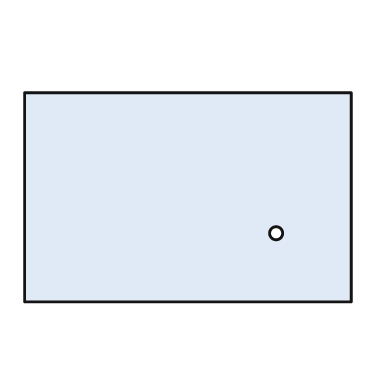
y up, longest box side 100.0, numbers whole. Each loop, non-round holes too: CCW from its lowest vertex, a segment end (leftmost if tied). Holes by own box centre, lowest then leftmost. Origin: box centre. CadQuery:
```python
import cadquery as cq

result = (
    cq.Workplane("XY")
    .moveTo(-50.0, -32.0)
    .lineTo(50.0, -32.0)
    .lineTo(50.0, 32.0)
    .lineTo(-50.0, 32.0)
    .close()
    .moveTo(27.0, -11.0)
    .circle(2.0)
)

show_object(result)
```